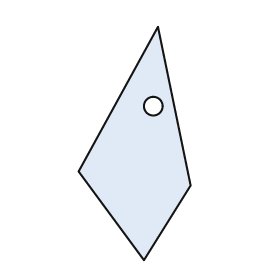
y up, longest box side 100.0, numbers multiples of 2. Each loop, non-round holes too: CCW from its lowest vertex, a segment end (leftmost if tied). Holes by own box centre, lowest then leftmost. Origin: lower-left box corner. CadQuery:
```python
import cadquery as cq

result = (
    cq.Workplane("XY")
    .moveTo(28.0, 0.0)
    .lineTo(48.0, 32.0)
    .lineTo(34.0, 100.0)
    .lineTo(0.0, 38.0)
    .close()
    .moveTo(32.0, 66.0)
    .circle(4.0)
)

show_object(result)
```